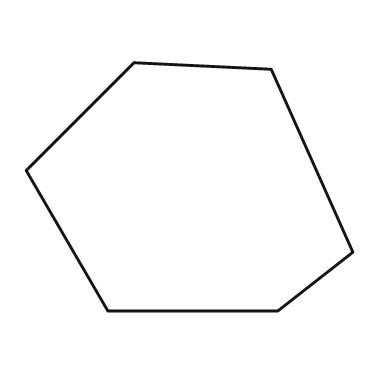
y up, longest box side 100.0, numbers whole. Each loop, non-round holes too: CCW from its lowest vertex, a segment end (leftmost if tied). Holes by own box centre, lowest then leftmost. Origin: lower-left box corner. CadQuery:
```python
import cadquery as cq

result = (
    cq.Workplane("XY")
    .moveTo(25.0, 0.0)
    .lineTo(77.0, 0.0)
    .lineTo(100.0, 18.0)
    .lineTo(75.0, 74.0)
    .lineTo(33.0, 76.0)
    .lineTo(0.0, 43.0)
    .close()
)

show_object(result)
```